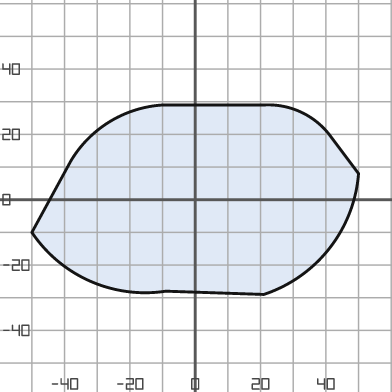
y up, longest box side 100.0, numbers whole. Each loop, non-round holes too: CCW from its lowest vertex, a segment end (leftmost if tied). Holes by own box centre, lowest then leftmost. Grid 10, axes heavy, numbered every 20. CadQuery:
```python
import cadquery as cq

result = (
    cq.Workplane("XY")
    .moveTo(21.0, -29.0)
    .threePointArc((41.0, -15.0), (50.0, 8.0))
    .lineTo(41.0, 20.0)
    .threePointArc((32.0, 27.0), (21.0, 29.0))
    .lineTo(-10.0, 29.0)
    .threePointArc((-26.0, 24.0), (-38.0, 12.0))
    .lineTo(-50.0, -10.0)
    .threePointArc((-32.0, -25.0), (-9.0, -28.0))
    .close()
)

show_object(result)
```